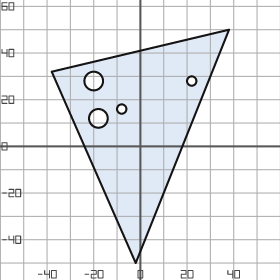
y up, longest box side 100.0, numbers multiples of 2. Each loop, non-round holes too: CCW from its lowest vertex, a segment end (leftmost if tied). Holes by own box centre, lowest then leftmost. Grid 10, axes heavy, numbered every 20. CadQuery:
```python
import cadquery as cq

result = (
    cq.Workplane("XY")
    .moveTo(-2.0, -50.0)
    .lineTo(38.0, 50.0)
    .lineTo(-38.0, 32.0)
    .close()
    .moveTo(-18.0, 12.0)
    .circle(4.0)
    .moveTo(-8.0, 16.0)
    .circle(2.0)
    .moveTo(-20.0, 28.0)
    .circle(4.0)
    .moveTo(22.0, 28.0)
    .circle(2.0)
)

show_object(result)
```